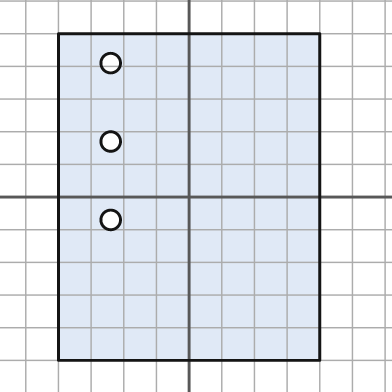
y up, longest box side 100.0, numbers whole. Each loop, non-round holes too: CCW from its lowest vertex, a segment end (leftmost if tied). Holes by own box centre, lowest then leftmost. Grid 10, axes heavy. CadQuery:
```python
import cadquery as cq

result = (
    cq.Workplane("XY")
    .moveTo(-40.0, -50.0)
    .lineTo(40.0, -50.0)
    .lineTo(40.0, 50.0)
    .lineTo(-40.0, 50.0)
    .close()
    .moveTo(-24.0, -7.0)
    .circle(3.0)
    .moveTo(-24.0, 17.0)
    .circle(3.0)
    .moveTo(-24.0, 41.0)
    .circle(3.0)
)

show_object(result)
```